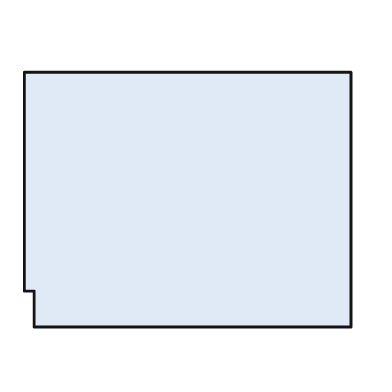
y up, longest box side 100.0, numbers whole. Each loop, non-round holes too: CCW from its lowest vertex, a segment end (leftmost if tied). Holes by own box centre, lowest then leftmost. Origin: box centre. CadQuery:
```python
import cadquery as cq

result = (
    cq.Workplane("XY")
    .moveTo(-47.0, -39.0)
    .lineTo(50.0, -39.0)
    .lineTo(50.0, 39.0)
    .lineTo(-50.0, 39.0)
    .lineTo(-50.0, -28.0)
    .lineTo(-47.0, -28.0)
    .close()
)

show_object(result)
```